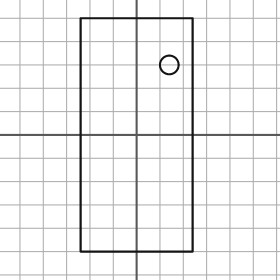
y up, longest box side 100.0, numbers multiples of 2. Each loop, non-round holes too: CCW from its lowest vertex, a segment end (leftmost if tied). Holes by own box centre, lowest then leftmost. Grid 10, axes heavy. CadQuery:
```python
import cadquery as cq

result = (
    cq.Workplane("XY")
    .moveTo(-24.0, -50.0)
    .lineTo(24.0, -50.0)
    .lineTo(24.0, 50.0)
    .lineTo(-24.0, 50.0)
    .close()
    .moveTo(14.0, 30.0)
    .circle(4.0)
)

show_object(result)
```